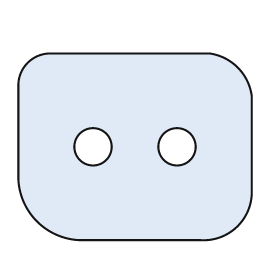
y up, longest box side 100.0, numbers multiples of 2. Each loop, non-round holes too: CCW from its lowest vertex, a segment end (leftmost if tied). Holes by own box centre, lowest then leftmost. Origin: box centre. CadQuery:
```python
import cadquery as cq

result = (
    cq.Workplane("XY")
    .moveTo(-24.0, -40.0)
    .lineTo(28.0, -40.0)
    .threePointArc((44.0, -34.0), (50.0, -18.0))
    .lineTo(50.0, 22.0)
    .threePointArc((44.0, 34.0), (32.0, 40.0))
    .lineTo(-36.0, 40.0)
    .threePointArc((-46.0, 36.0), (-50.0, 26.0))
    .lineTo(-50.0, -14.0)
    .threePointArc((-42.0, -32.0), (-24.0, -40.0))
    .close()
    .moveTo(-18.0, 0.0)
    .circle(8.0)
    .moveTo(18.0, 0.0)
    .circle(8.0)
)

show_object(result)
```